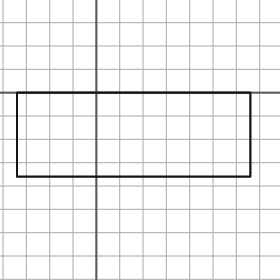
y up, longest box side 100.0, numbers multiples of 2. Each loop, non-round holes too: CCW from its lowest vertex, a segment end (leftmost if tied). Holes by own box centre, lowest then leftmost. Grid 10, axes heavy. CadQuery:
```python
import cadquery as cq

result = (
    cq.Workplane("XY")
    .moveTo(-34.0, -36.0)
    .lineTo(66.0, -36.0)
    .lineTo(66.0, 0.0)
    .lineTo(-34.0, 0.0)
    .close()
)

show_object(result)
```